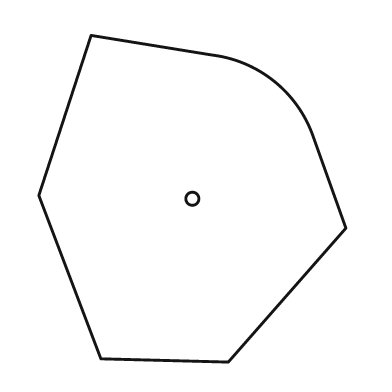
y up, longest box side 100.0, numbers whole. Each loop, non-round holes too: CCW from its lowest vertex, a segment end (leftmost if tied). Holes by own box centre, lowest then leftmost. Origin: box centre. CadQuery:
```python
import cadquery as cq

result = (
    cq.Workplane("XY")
    .moveTo(11.0, -50.0)
    .lineTo(47.0, -9.0)
    .lineTo(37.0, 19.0)
    .threePointArc((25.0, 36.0), (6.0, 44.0))
    .lineTo(-31.0, 50.0)
    .lineTo(-47.0, 1.0)
    .lineTo(-28.0, -49.0)
    .close()
    .moveTo(0.0, 0.0)
    .circle(2.0)
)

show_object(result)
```